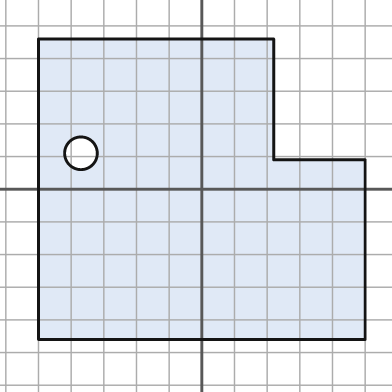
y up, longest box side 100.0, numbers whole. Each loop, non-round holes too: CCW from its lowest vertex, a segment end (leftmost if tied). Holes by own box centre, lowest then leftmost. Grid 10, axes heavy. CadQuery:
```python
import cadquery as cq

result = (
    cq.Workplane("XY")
    .moveTo(-50.0, -46.0)
    .lineTo(50.0, -46.0)
    .lineTo(50.0, 9.0)
    .lineTo(22.0, 9.0)
    .lineTo(22.0, 46.0)
    .lineTo(-50.0, 46.0)
    .close()
    .moveTo(-37.0, 11.0)
    .circle(5.0)
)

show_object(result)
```